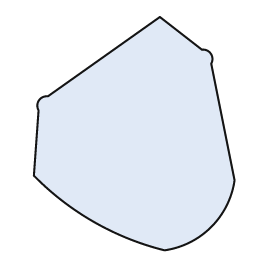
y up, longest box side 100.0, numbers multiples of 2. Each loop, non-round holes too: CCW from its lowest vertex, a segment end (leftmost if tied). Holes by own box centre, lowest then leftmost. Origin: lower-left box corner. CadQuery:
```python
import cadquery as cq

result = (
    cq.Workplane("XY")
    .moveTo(56.0, 0.0)
    .threePointArc((76.0, 10.0), (86.0, 30.0))
    .lineTo(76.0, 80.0)
    .threePointArc((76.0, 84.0), (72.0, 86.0))
    .lineTo(54.0, 100.0)
    .lineTo(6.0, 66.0)
    .threePointArc((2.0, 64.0), (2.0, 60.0))
    .lineTo(0.0, 32.0)
    .threePointArc((26.0, 12.0), (56.0, 0.0))
    .close()
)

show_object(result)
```